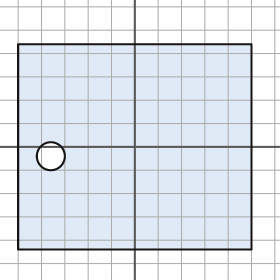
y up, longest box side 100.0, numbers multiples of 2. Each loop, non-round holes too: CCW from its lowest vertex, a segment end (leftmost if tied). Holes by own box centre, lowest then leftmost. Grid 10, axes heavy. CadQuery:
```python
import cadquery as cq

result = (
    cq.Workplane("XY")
    .moveTo(-50.0, -44.0)
    .lineTo(50.0, -44.0)
    .lineTo(50.0, 44.0)
    .lineTo(-50.0, 44.0)
    .close()
    .moveTo(-36.0, -4.0)
    .circle(6.0)
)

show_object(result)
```